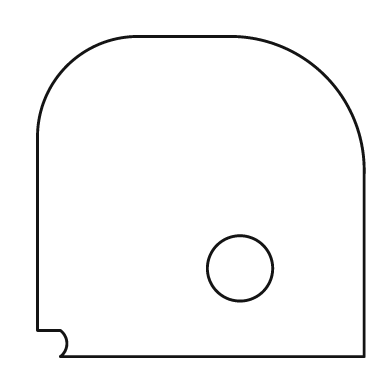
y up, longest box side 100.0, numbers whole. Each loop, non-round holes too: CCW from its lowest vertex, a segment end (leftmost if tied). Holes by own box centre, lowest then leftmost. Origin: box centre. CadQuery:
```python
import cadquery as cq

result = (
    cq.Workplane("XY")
    .moveTo(-43.0, -49.0)
    .lineTo(50.0, -49.0)
    .lineTo(50.0, 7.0)
    .threePointArc((38.0, 37.0), (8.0, 49.0))
    .lineTo(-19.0, 49.0)
    .threePointArc((-41.0, 40.0), (-50.0, 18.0))
    .lineTo(-50.0, -41.0)
    .lineTo(-43.0, -41.0)
    .threePointArc((-41.0, -45.0), (-43.0, -49.0))
    .close()
    .moveTo(12.0, -22.0)
    .circle(10.0)
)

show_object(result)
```